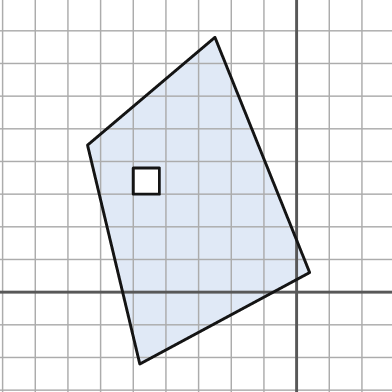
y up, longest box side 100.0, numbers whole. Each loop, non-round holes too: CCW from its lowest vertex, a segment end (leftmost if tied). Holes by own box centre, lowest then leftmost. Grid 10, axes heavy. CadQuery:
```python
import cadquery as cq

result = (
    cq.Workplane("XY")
    .moveTo(-48.0, -22.0)
    .lineTo(4.0, 6.0)
    .lineTo(-25.0, 78.0)
    .lineTo(-64.0, 45.0)
    .close()
    .moveTo(-50.0, 30.0)
    .lineTo(-42.0, 30.0)
    .lineTo(-42.0, 38.0)
    .lineTo(-50.0, 38.0)
    .close()
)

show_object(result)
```